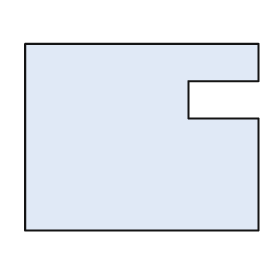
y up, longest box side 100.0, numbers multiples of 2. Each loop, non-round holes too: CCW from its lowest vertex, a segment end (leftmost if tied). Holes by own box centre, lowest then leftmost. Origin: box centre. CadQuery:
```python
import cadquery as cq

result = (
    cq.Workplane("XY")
    .moveTo(-50.0, -40.0)
    .lineTo(50.0, -40.0)
    .lineTo(50.0, 8.0)
    .lineTo(20.0, 8.0)
    .lineTo(20.0, 24.0)
    .lineTo(50.0, 24.0)
    .lineTo(50.0, 40.0)
    .lineTo(-50.0, 40.0)
    .close()
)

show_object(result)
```